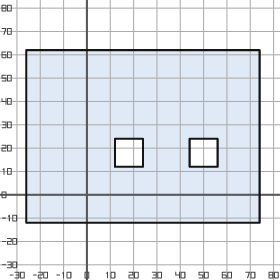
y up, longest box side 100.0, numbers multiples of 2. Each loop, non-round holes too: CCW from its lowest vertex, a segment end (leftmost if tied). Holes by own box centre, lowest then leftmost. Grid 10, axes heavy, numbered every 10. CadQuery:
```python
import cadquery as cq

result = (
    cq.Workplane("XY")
    .moveTo(-26.0, -12.0)
    .lineTo(74.0, -12.0)
    .lineTo(74.0, 62.0)
    .lineTo(-26.0, 62.0)
    .close()
    .moveTo(12.0, 12.0)
    .lineTo(24.0, 12.0)
    .lineTo(24.0, 24.0)
    .lineTo(12.0, 24.0)
    .close()
    .moveTo(44.0, 12.0)
    .lineTo(56.0, 12.0)
    .lineTo(56.0, 24.0)
    .lineTo(44.0, 24.0)
    .close()
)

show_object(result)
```